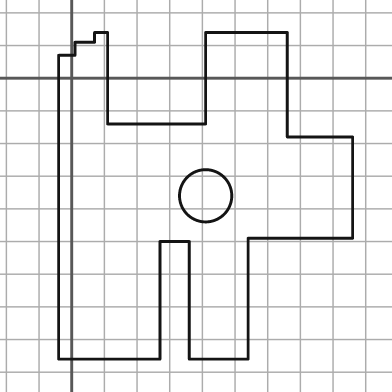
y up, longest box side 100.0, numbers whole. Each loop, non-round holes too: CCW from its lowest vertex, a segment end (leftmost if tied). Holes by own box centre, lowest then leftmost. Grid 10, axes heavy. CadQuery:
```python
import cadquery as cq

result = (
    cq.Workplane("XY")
    .moveTo(-4.0, -86.0)
    .lineTo(27.0, -86.0)
    .lineTo(27.0, -50.0)
    .lineTo(36.0, -50.0)
    .lineTo(36.0, -86.0)
    .lineTo(54.0, -86.0)
    .lineTo(54.0, -49.0)
    .lineTo(86.0, -49.0)
    .lineTo(86.0, -18.0)
    .lineTo(66.0, -18.0)
    .lineTo(66.0, 14.0)
    .lineTo(41.0, 14.0)
    .lineTo(41.0, -14.0)
    .lineTo(11.0, -14.0)
    .lineTo(11.0, 14.0)
    .lineTo(7.0, 14.0)
    .lineTo(7.0, 11.0)
    .lineTo(1.0, 11.0)
    .lineTo(1.0, 7.0)
    .lineTo(-4.0, 7.0)
    .close()
    .moveTo(41.0, -36.0)
    .circle(8.0)
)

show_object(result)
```